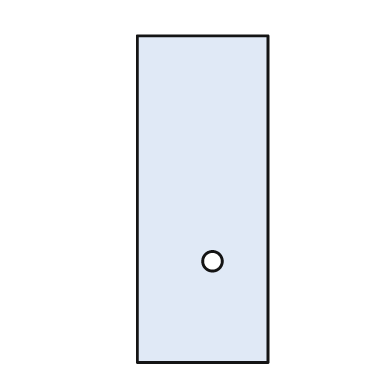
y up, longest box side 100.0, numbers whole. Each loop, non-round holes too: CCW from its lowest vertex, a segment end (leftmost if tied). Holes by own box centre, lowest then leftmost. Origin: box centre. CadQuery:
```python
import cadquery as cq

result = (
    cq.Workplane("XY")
    .moveTo(-20.0, -50.0)
    .lineTo(20.0, -50.0)
    .lineTo(20.0, 50.0)
    .lineTo(-20.0, 50.0)
    .close()
    .moveTo(3.0, -19.0)
    .circle(3.0)
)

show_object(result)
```